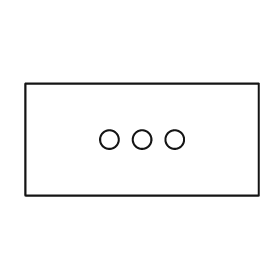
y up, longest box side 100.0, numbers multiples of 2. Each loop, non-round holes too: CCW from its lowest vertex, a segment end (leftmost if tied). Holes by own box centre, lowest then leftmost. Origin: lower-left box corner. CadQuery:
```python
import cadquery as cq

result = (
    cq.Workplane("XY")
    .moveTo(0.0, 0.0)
    .lineTo(100.0, 0.0)
    .lineTo(100.0, 48.0)
    .lineTo(0.0, 48.0)
    .close()
    .moveTo(36.0, 24.0)
    .circle(4.0)
    .moveTo(50.0, 24.0)
    .circle(4.0)
    .moveTo(64.0, 24.0)
    .circle(4.0)
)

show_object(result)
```